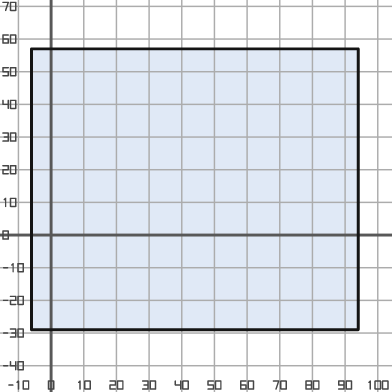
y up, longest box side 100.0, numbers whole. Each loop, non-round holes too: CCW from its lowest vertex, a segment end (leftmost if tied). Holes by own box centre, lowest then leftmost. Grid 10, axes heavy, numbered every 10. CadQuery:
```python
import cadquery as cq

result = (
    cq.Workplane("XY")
    .moveTo(-6.0, -29.0)
    .lineTo(94.0, -29.0)
    .lineTo(94.0, 57.0)
    .lineTo(-6.0, 57.0)
    .close()
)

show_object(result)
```